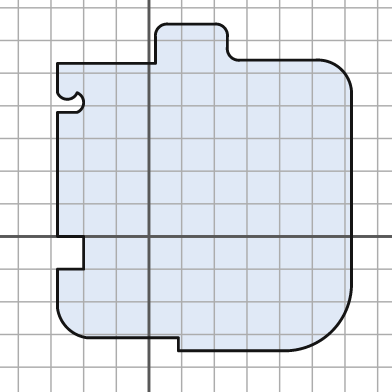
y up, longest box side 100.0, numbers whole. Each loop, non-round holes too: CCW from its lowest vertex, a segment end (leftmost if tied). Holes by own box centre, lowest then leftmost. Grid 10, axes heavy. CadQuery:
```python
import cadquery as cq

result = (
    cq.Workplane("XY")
    .moveTo(9.0, -35.0)
    .lineTo(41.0, -35.0)
    .threePointArc((56.0, -29.0), (62.0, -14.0))
    .lineTo(62.0, 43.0)
    .threePointArc((59.0, 51.0), (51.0, 54.0))
    .lineTo(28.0, 54.0)
    .threePointArc((25.0, 55.0), (24.0, 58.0))
    .lineTo(24.0, 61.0)
    .threePointArc((23.0, 64.0), (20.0, 65.0))
    .lineTo(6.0, 65.0)
    .threePointArc((3.0, 64.0), (2.0, 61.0))
    .lineTo(2.0, 53.0)
    .lineTo(-28.0, 53.0)
    .lineTo(-28.0, 44.0)
    .threePointArc((-25.0, 42.0), (-22.0, 44.0))
    .threePointArc((-20.0, 41.0), (-22.0, 38.0))
    .lineTo(-28.0, 38.0)
    .lineTo(-28.0, 0.0)
    .lineTo(-20.0, 0.0)
    .lineTo(-20.0, -10.0)
    .lineTo(-28.0, -10.0)
    .lineTo(-28.0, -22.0)
    .threePointArc((-25.0, -28.0), (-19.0, -31.0))
    .lineTo(9.0, -31.0)
    .close()
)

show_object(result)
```